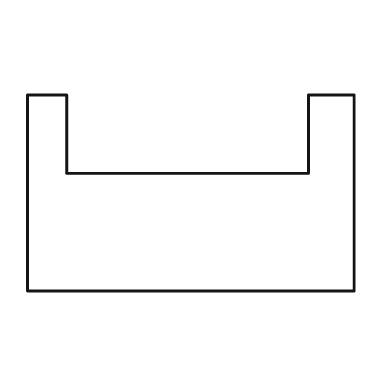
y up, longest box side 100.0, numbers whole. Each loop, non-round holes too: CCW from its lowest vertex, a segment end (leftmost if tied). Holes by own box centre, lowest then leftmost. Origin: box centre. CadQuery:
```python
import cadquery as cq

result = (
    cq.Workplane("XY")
    .moveTo(-50.0, -30.0)
    .lineTo(50.0, -30.0)
    .lineTo(50.0, 30.0)
    .lineTo(36.0, 30.0)
    .lineTo(36.0, 6.0)
    .lineTo(-38.0, 6.0)
    .lineTo(-38.0, 30.0)
    .lineTo(-50.0, 30.0)
    .close()
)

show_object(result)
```